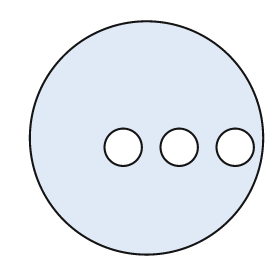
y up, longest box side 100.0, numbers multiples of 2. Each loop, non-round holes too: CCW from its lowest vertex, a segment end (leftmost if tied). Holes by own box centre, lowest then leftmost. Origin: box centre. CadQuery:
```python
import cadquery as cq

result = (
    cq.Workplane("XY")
    .moveTo(0.0, 0.0)
    .circle(50.0)
    .moveTo(-10.0, -4.0)
    .circle(8.0)
    .moveTo(14.0, -4.0)
    .circle(8.0)
    .moveTo(38.0, -4.0)
    .circle(8.0)
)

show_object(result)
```